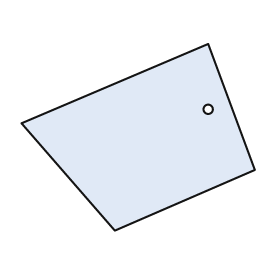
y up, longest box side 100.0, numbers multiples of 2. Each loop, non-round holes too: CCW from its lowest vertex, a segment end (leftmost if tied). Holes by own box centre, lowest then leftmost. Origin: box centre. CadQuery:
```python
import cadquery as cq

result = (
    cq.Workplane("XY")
    .moveTo(-10.0, -40.0)
    .lineTo(50.0, -14.0)
    .lineTo(30.0, 40.0)
    .lineTo(-50.0, 6.0)
    .close()
    .moveTo(30.0, 12.0)
    .circle(2.0)
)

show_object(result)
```